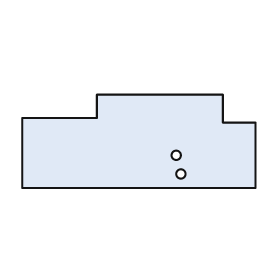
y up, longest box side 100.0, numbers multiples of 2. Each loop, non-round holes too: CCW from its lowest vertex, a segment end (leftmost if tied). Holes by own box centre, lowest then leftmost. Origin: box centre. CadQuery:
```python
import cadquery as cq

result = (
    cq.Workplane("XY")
    .moveTo(-50.0, -20.0)
    .lineTo(50.0, -20.0)
    .lineTo(50.0, 8.0)
    .lineTo(36.0, 8.0)
    .lineTo(36.0, 20.0)
    .lineTo(-18.0, 20.0)
    .lineTo(-18.0, 10.0)
    .lineTo(-50.0, 10.0)
    .close()
    .moveTo(18.0, -14.0)
    .circle(2.0)
    .moveTo(16.0, -6.0)
    .circle(2.0)
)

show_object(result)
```